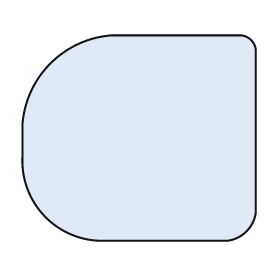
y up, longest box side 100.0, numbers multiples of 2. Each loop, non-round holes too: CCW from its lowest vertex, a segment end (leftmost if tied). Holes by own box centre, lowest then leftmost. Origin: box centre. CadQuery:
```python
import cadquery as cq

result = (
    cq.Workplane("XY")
    .moveTo(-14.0, -44.0)
    .lineTo(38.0, -44.0)
    .threePointArc((46.0, -40.0), (50.0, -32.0))
    .lineTo(50.0, 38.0)
    .threePointArc((48.0, 42.0), (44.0, 44.0))
    .lineTo(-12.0, 44.0)
    .threePointArc((-38.0, 32.0), (-50.0, 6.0))
    .lineTo(-50.0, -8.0)
    .threePointArc((-40.0, -34.0), (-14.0, -44.0))
    .close()
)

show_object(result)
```